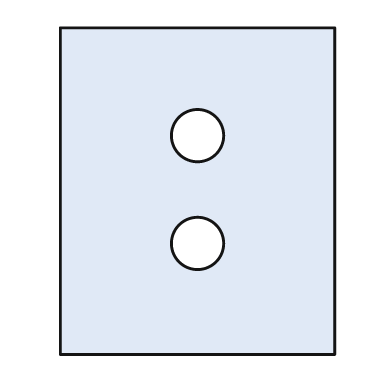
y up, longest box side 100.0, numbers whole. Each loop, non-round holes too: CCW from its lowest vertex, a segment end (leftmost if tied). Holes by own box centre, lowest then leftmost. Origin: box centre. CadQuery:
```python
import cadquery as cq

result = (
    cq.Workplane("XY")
    .moveTo(-42.0, -50.0)
    .lineTo(42.0, -50.0)
    .lineTo(42.0, 50.0)
    .lineTo(-42.0, 50.0)
    .close()
    .moveTo(0.0, -16.0)
    .circle(8.0)
    .moveTo(0.0, 17.0)
    .circle(8.0)
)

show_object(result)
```